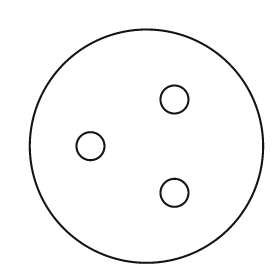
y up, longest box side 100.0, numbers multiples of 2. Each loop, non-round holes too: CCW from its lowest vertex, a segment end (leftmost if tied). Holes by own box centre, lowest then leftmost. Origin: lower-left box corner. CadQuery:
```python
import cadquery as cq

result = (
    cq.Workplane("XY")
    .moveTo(50.0, 50.0)
    .circle(50.0)
    .moveTo(62.0, 30.0)
    .circle(6.0)
    .moveTo(26.0, 50.0)
    .circle(6.0)
    .moveTo(62.0, 70.0)
    .circle(6.0)
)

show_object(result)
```